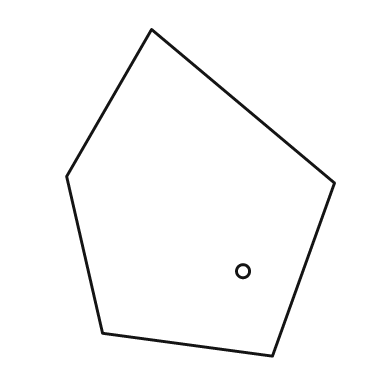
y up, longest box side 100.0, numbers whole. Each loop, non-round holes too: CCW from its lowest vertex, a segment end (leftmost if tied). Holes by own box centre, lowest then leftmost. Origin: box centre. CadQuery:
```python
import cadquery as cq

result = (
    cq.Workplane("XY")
    .moveTo(22.0, -50.0)
    .lineTo(41.0, 3.0)
    .lineTo(-15.0, 50.0)
    .lineTo(-41.0, 5.0)
    .lineTo(-30.0, -43.0)
    .close()
    .moveTo(13.0, -24.0)
    .circle(2.0)
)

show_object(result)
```